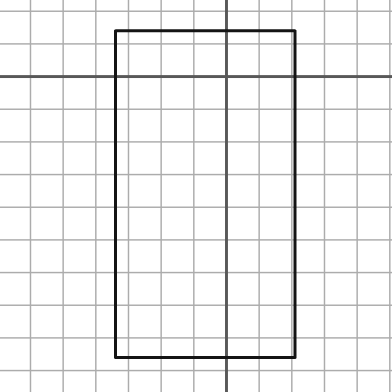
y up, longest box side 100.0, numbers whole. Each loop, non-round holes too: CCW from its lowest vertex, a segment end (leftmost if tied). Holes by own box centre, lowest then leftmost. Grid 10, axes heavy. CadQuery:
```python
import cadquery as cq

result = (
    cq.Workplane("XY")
    .moveTo(-34.0, -86.0)
    .lineTo(21.0, -86.0)
    .lineTo(21.0, 14.0)
    .lineTo(-34.0, 14.0)
    .close()
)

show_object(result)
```